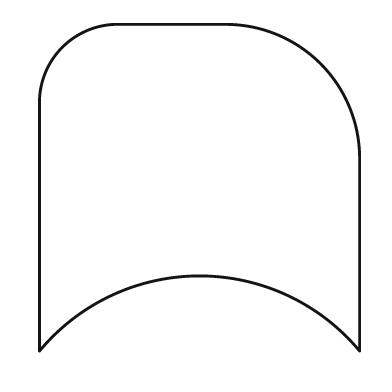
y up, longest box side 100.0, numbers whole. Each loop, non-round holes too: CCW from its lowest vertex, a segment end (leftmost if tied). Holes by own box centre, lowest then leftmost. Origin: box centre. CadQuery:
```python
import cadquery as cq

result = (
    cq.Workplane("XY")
    .moveTo(-49.0, -50.0)
    .threePointArc((0.0, -27.0), (49.0, -50.0))
    .lineTo(49.0, 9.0)
    .threePointArc((37.0, 38.0), (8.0, 50.0))
    .lineTo(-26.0, 50.0)
    .threePointArc((-42.0, 43.0), (-49.0, 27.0))
    .close()
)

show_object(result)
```